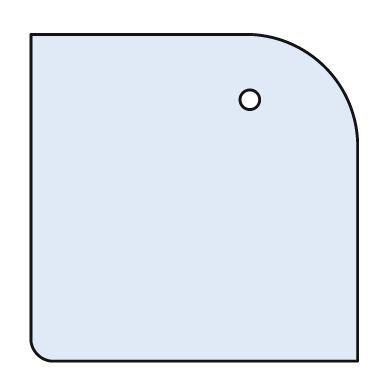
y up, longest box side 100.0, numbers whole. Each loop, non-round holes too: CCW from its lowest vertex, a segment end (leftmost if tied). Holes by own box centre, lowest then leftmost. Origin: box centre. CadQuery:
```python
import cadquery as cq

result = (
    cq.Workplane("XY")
    .moveTo(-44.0, -50.0)
    .lineTo(50.0, -50.0)
    .lineTo(50.0, 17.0)
    .threePointArc((40.0, 40.0), (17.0, 50.0))
    .lineTo(-50.0, 50.0)
    .lineTo(-50.0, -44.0)
    .threePointArc((-48.0, -48.0), (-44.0, -50.0))
    .close()
    .moveTo(17.0, 30.0)
    .circle(3.0)
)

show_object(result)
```